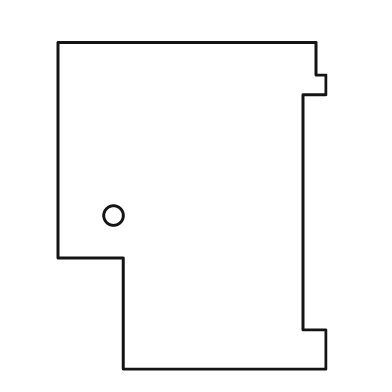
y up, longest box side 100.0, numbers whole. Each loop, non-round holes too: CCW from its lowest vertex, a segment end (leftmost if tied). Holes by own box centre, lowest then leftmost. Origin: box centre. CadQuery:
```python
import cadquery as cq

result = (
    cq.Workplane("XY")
    .moveTo(-21.0, -50.0)
    .lineTo(41.0, -50.0)
    .lineTo(41.0, -38.0)
    .lineTo(34.0, -38.0)
    .lineTo(34.0, 34.0)
    .lineTo(41.0, 34.0)
    .lineTo(41.0, 40.0)
    .lineTo(38.0, 40.0)
    .lineTo(38.0, 50.0)
    .lineTo(-41.0, 50.0)
    .lineTo(-41.0, -16.0)
    .lineTo(-21.0, -16.0)
    .close()
    .moveTo(-24.0, -3.0)
    .circle(3.0)
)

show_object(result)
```